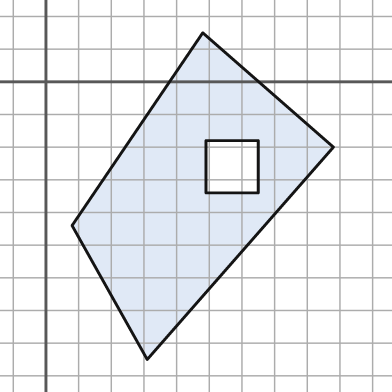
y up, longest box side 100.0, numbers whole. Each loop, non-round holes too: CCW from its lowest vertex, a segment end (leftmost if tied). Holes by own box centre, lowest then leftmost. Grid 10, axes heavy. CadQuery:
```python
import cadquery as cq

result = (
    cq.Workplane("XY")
    .moveTo(31.0, -85.0)
    .lineTo(88.0, -20.0)
    .lineTo(48.0, 15.0)
    .lineTo(8.0, -44.0)
    .close()
    .moveTo(49.0, -34.0)
    .lineTo(65.0, -34.0)
    .lineTo(65.0, -18.0)
    .lineTo(49.0, -18.0)
    .close()
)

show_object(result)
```